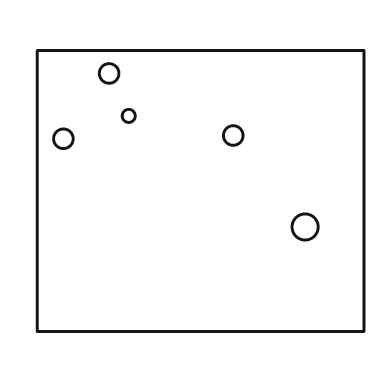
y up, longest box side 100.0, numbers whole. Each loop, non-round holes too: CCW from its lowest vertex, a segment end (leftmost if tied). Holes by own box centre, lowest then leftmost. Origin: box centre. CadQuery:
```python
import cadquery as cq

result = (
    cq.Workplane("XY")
    .moveTo(-50.0, -43.0)
    .lineTo(50.0, -43.0)
    .lineTo(50.0, 43.0)
    .lineTo(-50.0, 43.0)
    .close()
    .moveTo(32.0, -11.0)
    .circle(4.0)
    .moveTo(-42.0, 16.0)
    .circle(3.0)
    .moveTo(10.0, 17.0)
    .circle(3.0)
    .moveTo(-22.0, 23.0)
    .circle(2.0)
    .moveTo(-28.0, 36.0)
    .circle(3.0)
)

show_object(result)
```